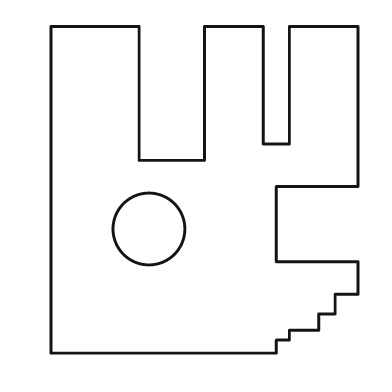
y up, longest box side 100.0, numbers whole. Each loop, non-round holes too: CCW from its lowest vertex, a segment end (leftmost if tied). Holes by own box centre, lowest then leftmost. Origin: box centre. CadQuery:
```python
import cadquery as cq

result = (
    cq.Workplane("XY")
    .moveTo(-47.0, -50.0)
    .lineTo(22.0, -50.0)
    .lineTo(22.0, -46.0)
    .lineTo(26.0, -46.0)
    .lineTo(26.0, -43.0)
    .lineTo(35.0, -43.0)
    .lineTo(35.0, -38.0)
    .lineTo(40.0, -38.0)
    .lineTo(40.0, -32.0)
    .lineTo(47.0, -32.0)
    .lineTo(47.0, -22.0)
    .lineTo(22.0, -22.0)
    .lineTo(22.0, 1.0)
    .lineTo(47.0, 1.0)
    .lineTo(47.0, 50.0)
    .lineTo(26.0, 50.0)
    .lineTo(26.0, 14.0)
    .lineTo(18.0, 14.0)
    .lineTo(18.0, 50.0)
    .lineTo(0.0, 50.0)
    .lineTo(0.0, 9.0)
    .lineTo(-20.0, 9.0)
    .lineTo(-20.0, 50.0)
    .lineTo(-47.0, 50.0)
    .close()
    .moveTo(-17.0, -12.0)
    .circle(11.0)
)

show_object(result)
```